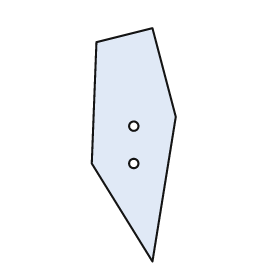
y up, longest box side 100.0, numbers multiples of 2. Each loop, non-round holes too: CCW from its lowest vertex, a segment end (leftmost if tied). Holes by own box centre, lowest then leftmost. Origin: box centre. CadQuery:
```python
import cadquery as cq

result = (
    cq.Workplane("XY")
    .moveTo(8.0, -50.0)
    .lineTo(18.0, 12.0)
    .lineTo(8.0, 50.0)
    .lineTo(-16.0, 44.0)
    .lineTo(-18.0, -8.0)
    .close()
    .moveTo(0.0, -8.0)
    .circle(2.0)
    .moveTo(0.0, 8.0)
    .circle(2.0)
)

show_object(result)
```